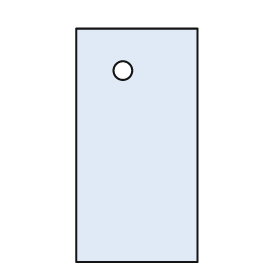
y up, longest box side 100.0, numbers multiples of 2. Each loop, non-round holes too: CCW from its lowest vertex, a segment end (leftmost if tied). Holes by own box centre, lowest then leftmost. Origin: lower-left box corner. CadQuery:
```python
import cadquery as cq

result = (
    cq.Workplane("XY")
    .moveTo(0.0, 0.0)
    .lineTo(52.0, 0.0)
    .lineTo(52.0, 100.0)
    .lineTo(0.0, 100.0)
    .close()
    .moveTo(20.0, 82.0)
    .circle(4.0)
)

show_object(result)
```